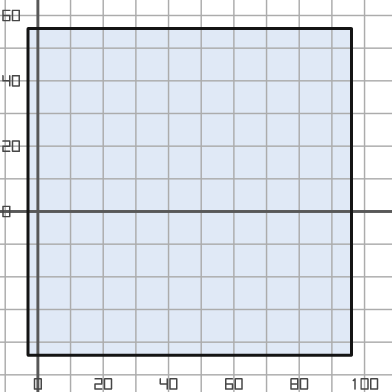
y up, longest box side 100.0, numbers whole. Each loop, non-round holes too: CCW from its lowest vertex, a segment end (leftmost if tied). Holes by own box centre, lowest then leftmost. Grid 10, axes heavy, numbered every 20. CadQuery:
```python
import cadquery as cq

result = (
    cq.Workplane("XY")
    .moveTo(-3.0, -44.0)
    .lineTo(96.0, -44.0)
    .lineTo(96.0, 56.0)
    .lineTo(-3.0, 56.0)
    .close()
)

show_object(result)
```